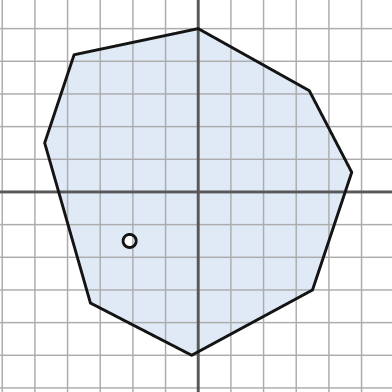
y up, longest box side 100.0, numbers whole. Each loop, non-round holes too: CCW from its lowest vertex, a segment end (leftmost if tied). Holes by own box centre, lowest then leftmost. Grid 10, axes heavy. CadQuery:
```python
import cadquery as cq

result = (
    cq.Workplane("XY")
    .moveTo(-2.0, -50.0)
    .lineTo(35.0, -30.0)
    .lineTo(47.0, 6.0)
    .lineTo(34.0, 31.0)
    .lineTo(0.0, 50.0)
    .lineTo(-38.0, 42.0)
    .lineTo(-47.0, 15.0)
    .lineTo(-33.0, -34.0)
    .close()
    .moveTo(-21.0, -15.0)
    .circle(2.0)
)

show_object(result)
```